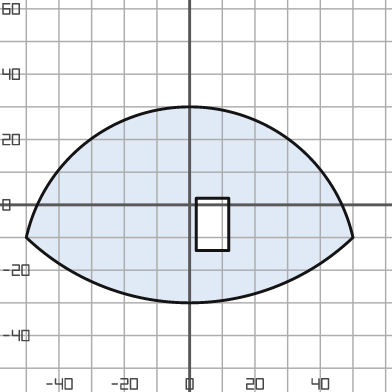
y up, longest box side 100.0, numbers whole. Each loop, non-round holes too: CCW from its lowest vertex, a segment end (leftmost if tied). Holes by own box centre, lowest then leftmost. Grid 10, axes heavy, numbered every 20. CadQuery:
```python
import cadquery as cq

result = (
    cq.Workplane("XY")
    .moveTo(-50.0, -10.0)
    .threePointArc((0.0, -30.0), (50.0, -10.0))
    .threePointArc((0.0, 30.0), (-50.0, -10.0))
    .close()
    .moveTo(2.0, -14.0)
    .lineTo(12.0, -14.0)
    .lineTo(12.0, 2.0)
    .lineTo(2.0, 2.0)
    .close()
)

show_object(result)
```